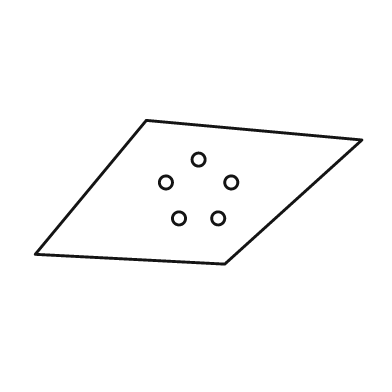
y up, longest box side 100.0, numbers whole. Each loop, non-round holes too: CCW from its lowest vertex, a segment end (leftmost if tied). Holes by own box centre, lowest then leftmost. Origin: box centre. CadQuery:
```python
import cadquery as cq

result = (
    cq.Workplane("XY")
    .moveTo(8.0, -22.0)
    .lineTo(50.0, 16.0)
    .lineTo(-16.0, 22.0)
    .lineTo(-50.0, -19.0)
    .close()
    .moveTo(-6.0, -8.0)
    .circle(2.0)
    .moveTo(6.0, -8.0)
    .circle(2.0)
    .moveTo(-10.0, 3.0)
    .circle(2.0)
    .moveTo(10.0, 3.0)
    .circle(2.0)
    .moveTo(0.0, 10.0)
    .circle(2.0)
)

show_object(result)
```